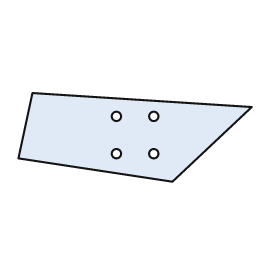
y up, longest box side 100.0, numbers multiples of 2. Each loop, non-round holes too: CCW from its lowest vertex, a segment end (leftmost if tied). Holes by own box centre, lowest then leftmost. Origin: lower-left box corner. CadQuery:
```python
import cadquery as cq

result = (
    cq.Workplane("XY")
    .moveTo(66.0, 0.0)
    .lineTo(100.0, 32.0)
    .lineTo(6.0, 38.0)
    .lineTo(0.0, 10.0)
    .close()
    .moveTo(42.0, 12.0)
    .circle(2.0)
    .moveTo(58.0, 12.0)
    .circle(2.0)
    .moveTo(42.0, 28.0)
    .circle(2.0)
    .moveTo(58.0, 28.0)
    .circle(2.0)
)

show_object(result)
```